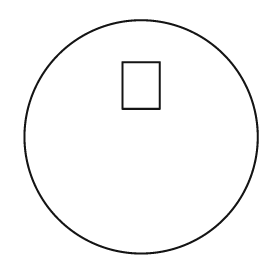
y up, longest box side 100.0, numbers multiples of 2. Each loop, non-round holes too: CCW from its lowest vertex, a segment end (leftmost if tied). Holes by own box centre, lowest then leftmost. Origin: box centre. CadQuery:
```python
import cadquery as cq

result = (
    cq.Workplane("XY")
    .moveTo(0.0, 0.0)
    .circle(50.0)
    .moveTo(-8.0, 12.0)
    .lineTo(8.0, 12.0)
    .lineTo(8.0, 32.0)
    .lineTo(-8.0, 32.0)
    .close()
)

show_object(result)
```